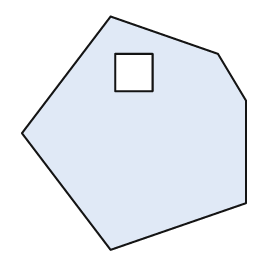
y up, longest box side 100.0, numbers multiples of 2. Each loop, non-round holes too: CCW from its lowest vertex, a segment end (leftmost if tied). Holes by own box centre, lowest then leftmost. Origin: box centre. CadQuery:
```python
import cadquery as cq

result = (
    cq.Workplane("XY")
    .moveTo(-10.0, -50.0)
    .lineTo(48.0, -30.0)
    .lineTo(48.0, 14.0)
    .lineTo(36.0, 34.0)
    .lineTo(-10.0, 50.0)
    .lineTo(-48.0, 0.0)
    .close()
    .moveTo(-8.0, 18.0)
    .lineTo(8.0, 18.0)
    .lineTo(8.0, 34.0)
    .lineTo(-8.0, 34.0)
    .close()
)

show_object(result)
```